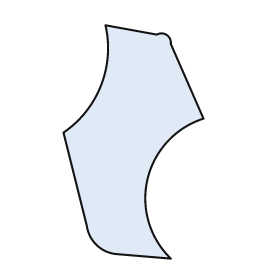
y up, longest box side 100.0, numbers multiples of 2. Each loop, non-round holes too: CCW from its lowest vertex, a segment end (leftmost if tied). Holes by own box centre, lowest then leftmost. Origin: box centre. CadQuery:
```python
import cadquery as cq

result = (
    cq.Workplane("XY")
    .moveTo(16.0, -50.0)
    .threePointArc((6.0, -16.0), (30.0, 10.0))
    .lineTo(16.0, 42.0)
    .threePointArc((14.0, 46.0), (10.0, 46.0))
    .lineTo(-12.0, 50.0)
    .threePointArc((-14.0, 24.0), (-30.0, 4.0))
    .lineTo(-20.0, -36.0)
    .threePointArc((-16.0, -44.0), (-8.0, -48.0))
    .close()
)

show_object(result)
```